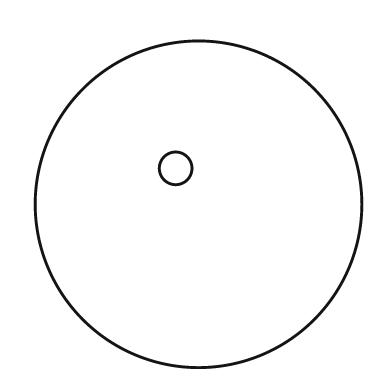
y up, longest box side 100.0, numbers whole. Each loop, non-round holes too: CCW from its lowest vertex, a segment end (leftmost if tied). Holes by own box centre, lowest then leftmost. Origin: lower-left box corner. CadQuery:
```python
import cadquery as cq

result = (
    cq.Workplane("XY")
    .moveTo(50.0, 50.0)
    .circle(50.0)
    .moveTo(43.0, 61.0)
    .circle(5.0)
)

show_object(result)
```